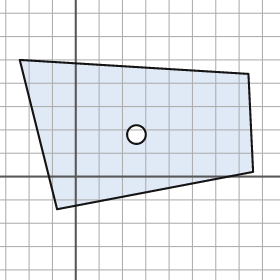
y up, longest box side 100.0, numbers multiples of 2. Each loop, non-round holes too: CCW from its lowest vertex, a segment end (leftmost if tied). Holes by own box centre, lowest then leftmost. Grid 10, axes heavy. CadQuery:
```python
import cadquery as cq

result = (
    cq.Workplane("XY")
    .moveTo(-8.0, -14.0)
    .lineTo(76.0, 2.0)
    .lineTo(74.0, 44.0)
    .lineTo(-24.0, 50.0)
    .close()
    .moveTo(26.0, 18.0)
    .circle(4.0)
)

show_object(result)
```